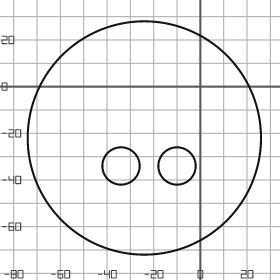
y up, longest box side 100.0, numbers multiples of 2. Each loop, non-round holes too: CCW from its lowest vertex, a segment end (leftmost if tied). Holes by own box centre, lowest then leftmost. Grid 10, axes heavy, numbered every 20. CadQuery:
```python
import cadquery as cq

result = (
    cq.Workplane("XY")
    .moveTo(-24.0, -22.0)
    .circle(50.0)
    .moveTo(-34.0, -34.0)
    .circle(8.0)
    .moveTo(-10.0, -34.0)
    .circle(8.0)
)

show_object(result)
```